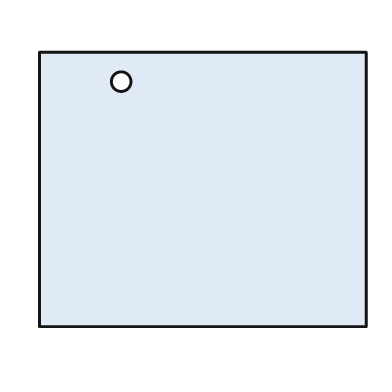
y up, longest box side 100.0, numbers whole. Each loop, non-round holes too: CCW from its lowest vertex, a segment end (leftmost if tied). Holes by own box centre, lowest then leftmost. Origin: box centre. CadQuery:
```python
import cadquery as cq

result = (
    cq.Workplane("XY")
    .moveTo(-50.0, -42.0)
    .lineTo(50.0, -42.0)
    .lineTo(50.0, 42.0)
    .lineTo(-50.0, 42.0)
    .close()
    .moveTo(-25.0, 33.0)
    .circle(3.0)
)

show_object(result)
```